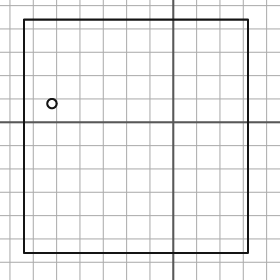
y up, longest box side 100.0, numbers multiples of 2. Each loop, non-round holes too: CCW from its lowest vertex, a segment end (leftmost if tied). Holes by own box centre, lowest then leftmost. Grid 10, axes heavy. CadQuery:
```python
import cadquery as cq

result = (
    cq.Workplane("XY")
    .moveTo(-64.0, -56.0)
    .lineTo(32.0, -56.0)
    .lineTo(32.0, 44.0)
    .lineTo(-64.0, 44.0)
    .close()
    .moveTo(-52.0, 8.0)
    .circle(2.0)
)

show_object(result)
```